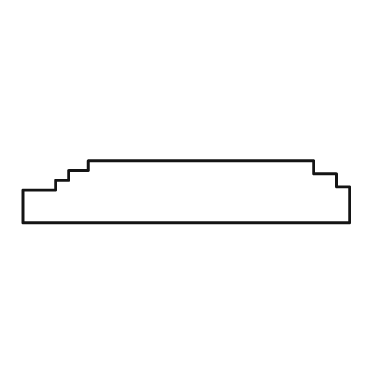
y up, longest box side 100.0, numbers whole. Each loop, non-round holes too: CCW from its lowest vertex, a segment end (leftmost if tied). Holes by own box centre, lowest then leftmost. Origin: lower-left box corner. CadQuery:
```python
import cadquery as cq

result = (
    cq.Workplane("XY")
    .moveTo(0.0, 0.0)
    .lineTo(100.0, 0.0)
    .lineTo(100.0, 11.0)
    .lineTo(96.0, 11.0)
    .lineTo(96.0, 15.0)
    .lineTo(89.0, 15.0)
    .lineTo(89.0, 19.0)
    .lineTo(20.0, 19.0)
    .lineTo(20.0, 16.0)
    .lineTo(14.0, 16.0)
    .lineTo(14.0, 13.0)
    .lineTo(10.0, 13.0)
    .lineTo(10.0, 10.0)
    .lineTo(0.0, 10.0)
    .close()
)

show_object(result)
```